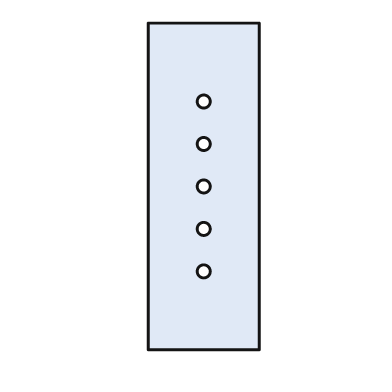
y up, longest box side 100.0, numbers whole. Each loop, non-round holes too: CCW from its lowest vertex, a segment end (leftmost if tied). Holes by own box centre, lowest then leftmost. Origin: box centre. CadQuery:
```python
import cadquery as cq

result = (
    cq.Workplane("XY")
    .moveTo(-17.0, -50.0)
    .lineTo(17.0, -50.0)
    .lineTo(17.0, 50.0)
    .lineTo(-17.0, 50.0)
    .close()
    .moveTo(0.0, -26.0)
    .circle(2.0)
    .moveTo(0.0, -13.0)
    .circle(2.0)
    .moveTo(0.0, 0.0)
    .circle(2.0)
    .moveTo(0.0, 13.0)
    .circle(2.0)
    .moveTo(0.0, 26.0)
    .circle(2.0)
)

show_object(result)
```